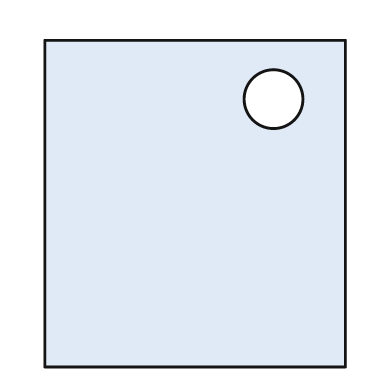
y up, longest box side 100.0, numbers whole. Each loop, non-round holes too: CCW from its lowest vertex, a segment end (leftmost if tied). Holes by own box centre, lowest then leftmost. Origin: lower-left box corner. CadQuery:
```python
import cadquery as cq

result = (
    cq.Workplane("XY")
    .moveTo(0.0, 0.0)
    .lineTo(92.0, 0.0)
    .lineTo(92.0, 100.0)
    .lineTo(0.0, 100.0)
    .close()
    .moveTo(70.0, 82.0)
    .circle(9.0)
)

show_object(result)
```